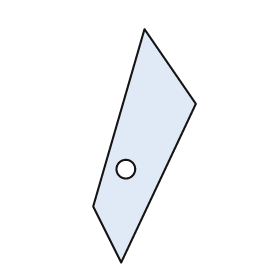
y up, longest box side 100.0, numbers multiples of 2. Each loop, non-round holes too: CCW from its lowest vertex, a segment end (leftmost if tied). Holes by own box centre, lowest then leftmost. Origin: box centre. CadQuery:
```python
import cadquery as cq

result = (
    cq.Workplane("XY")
    .moveTo(-10.0, -50.0)
    .lineTo(22.0, 18.0)
    .lineTo(0.0, 50.0)
    .lineTo(-22.0, -26.0)
    .close()
    .moveTo(-8.0, -10.0)
    .circle(4.0)
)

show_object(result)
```